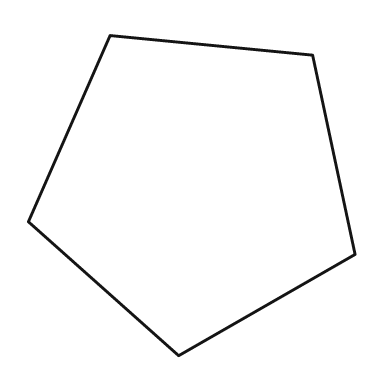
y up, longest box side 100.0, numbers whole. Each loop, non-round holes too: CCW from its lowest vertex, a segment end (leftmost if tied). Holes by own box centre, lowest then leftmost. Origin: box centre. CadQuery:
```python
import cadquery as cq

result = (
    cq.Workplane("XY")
    .moveTo(-4.0, -49.0)
    .lineTo(50.0, -18.0)
    .lineTo(37.0, 43.0)
    .lineTo(-25.0, 49.0)
    .lineTo(-50.0, -8.0)
    .close()
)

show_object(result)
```